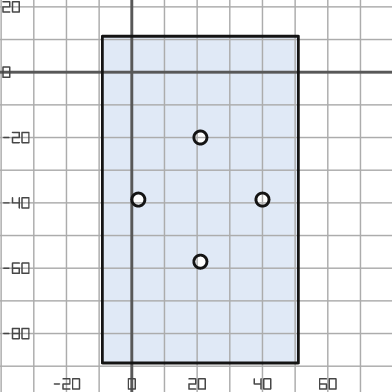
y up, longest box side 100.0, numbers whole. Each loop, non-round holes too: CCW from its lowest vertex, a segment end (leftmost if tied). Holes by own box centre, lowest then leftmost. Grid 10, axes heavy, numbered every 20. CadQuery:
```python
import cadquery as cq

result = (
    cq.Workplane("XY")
    .moveTo(-9.0, -89.0)
    .lineTo(51.0, -89.0)
    .lineTo(51.0, 11.0)
    .lineTo(-9.0, 11.0)
    .close()
    .moveTo(21.0, -58.0)
    .circle(2.0)
    .moveTo(2.0, -39.0)
    .circle(2.0)
    .moveTo(40.0, -39.0)
    .circle(2.0)
    .moveTo(21.0, -20.0)
    .circle(2.0)
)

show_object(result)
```